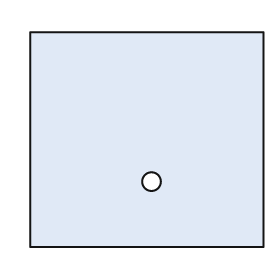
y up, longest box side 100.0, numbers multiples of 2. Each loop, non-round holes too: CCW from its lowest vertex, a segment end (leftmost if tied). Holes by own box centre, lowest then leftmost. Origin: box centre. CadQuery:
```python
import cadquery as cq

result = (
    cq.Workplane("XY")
    .moveTo(-50.0, -46.0)
    .lineTo(50.0, -46.0)
    .lineTo(50.0, 46.0)
    .lineTo(-50.0, 46.0)
    .close()
    .moveTo(2.0, -18.0)
    .circle(4.0)
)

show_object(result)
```